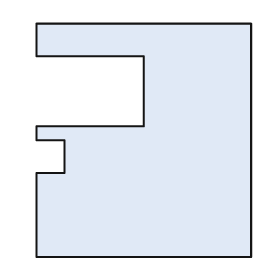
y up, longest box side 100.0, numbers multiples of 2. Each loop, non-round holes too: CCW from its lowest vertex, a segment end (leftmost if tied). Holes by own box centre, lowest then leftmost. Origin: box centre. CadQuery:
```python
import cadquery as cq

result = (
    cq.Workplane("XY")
    .moveTo(-46.0, -50.0)
    .lineTo(46.0, -50.0)
    .lineTo(46.0, 50.0)
    .lineTo(-46.0, 50.0)
    .lineTo(-46.0, 36.0)
    .lineTo(0.0, 36.0)
    .lineTo(0.0, 6.0)
    .lineTo(-46.0, 6.0)
    .lineTo(-46.0, 0.0)
    .lineTo(-34.0, 0.0)
    .lineTo(-34.0, -14.0)
    .lineTo(-46.0, -14.0)
    .close()
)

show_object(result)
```